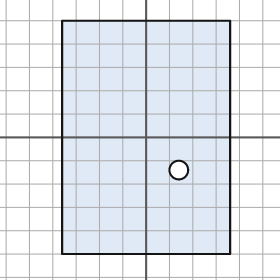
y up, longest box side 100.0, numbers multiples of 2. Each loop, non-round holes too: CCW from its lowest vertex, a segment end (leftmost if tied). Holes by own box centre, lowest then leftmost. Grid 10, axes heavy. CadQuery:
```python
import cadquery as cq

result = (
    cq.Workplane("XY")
    .moveTo(-36.0, -50.0)
    .lineTo(36.0, -50.0)
    .lineTo(36.0, 50.0)
    .lineTo(-36.0, 50.0)
    .close()
    .moveTo(14.0, -14.0)
    .circle(4.0)
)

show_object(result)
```